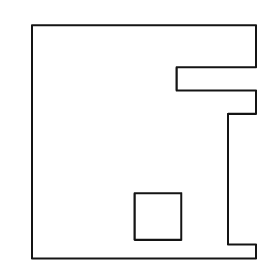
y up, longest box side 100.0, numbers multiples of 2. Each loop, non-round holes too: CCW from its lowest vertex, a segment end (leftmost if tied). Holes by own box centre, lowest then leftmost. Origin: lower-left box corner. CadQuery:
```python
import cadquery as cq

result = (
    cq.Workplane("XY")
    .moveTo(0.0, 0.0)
    .lineTo(96.0, 0.0)
    .lineTo(96.0, 6.0)
    .lineTo(84.0, 6.0)
    .lineTo(84.0, 62.0)
    .lineTo(96.0, 62.0)
    .lineTo(96.0, 72.0)
    .lineTo(62.0, 72.0)
    .lineTo(62.0, 82.0)
    .lineTo(96.0, 82.0)
    .lineTo(96.0, 100.0)
    .lineTo(0.0, 100.0)
    .close()
    .moveTo(44.0, 8.0)
    .lineTo(64.0, 8.0)
    .lineTo(64.0, 28.0)
    .lineTo(44.0, 28.0)
    .close()
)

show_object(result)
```